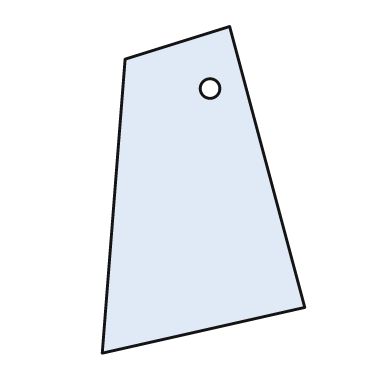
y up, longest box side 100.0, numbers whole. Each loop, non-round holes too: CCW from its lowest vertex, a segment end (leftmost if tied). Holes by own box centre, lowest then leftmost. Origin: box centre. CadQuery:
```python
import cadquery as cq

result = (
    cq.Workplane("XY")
    .moveTo(-31.0, -50.0)
    .lineTo(31.0, -36.0)
    .lineTo(8.0, 50.0)
    .lineTo(-24.0, 40.0)
    .close()
    .moveTo(2.0, 31.0)
    .circle(3.0)
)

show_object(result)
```